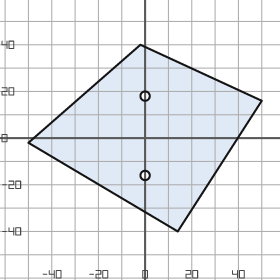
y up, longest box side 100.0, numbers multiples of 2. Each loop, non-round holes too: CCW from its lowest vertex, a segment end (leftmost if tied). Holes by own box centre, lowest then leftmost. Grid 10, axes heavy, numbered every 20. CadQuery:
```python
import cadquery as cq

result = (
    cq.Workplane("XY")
    .moveTo(14.0, -40.0)
    .lineTo(50.0, 16.0)
    .lineTo(-2.0, 40.0)
    .lineTo(-50.0, -2.0)
    .close()
    .moveTo(0.0, -16.0)
    .circle(2.0)
    .moveTo(0.0, 18.0)
    .circle(2.0)
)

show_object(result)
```